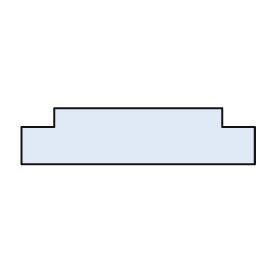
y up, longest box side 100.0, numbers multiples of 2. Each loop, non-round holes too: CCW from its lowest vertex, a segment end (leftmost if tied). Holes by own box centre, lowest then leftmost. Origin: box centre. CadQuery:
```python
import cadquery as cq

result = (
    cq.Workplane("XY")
    .moveTo(-50.0, -12.0)
    .lineTo(50.0, -12.0)
    .lineTo(50.0, 4.0)
    .lineTo(36.0, 4.0)
    .lineTo(36.0, 12.0)
    .lineTo(-36.0, 12.0)
    .lineTo(-36.0, 4.0)
    .lineTo(-50.0, 4.0)
    .close()
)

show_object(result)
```